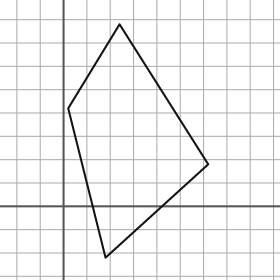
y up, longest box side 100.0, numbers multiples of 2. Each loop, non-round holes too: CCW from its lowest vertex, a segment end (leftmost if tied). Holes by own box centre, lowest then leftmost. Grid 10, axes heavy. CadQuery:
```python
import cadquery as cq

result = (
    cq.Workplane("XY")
    .moveTo(18.0, -22.0)
    .lineTo(62.0, 18.0)
    .lineTo(24.0, 78.0)
    .lineTo(2.0, 42.0)
    .close()
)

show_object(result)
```